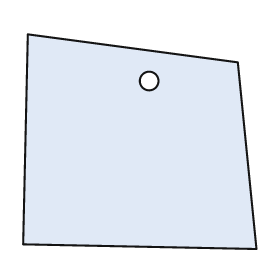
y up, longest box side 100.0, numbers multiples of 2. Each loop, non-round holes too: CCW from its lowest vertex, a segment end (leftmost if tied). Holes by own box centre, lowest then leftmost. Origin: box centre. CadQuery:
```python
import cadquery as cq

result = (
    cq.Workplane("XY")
    .moveTo(50.0, -46.0)
    .lineTo(42.0, 34.0)
    .lineTo(-48.0, 46.0)
    .lineTo(-50.0, -44.0)
    .close()
    .moveTo(4.0, 26.0)
    .circle(4.0)
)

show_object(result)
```